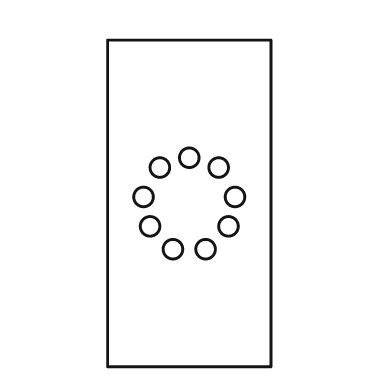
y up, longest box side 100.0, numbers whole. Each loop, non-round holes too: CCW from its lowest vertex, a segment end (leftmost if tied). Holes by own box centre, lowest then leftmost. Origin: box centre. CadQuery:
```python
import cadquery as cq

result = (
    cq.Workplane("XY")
    .moveTo(-25.0, -50.0)
    .lineTo(25.0, -50.0)
    .lineTo(25.0, 50.0)
    .lineTo(-25.0, 50.0)
    .close()
    .moveTo(-5.0, -14.0)
    .circle(3.0)
    .moveTo(5.0, -14.0)
    .circle(3.0)
    .moveTo(-12.0, -7.0)
    .circle(3.0)
    .moveTo(12.0, -7.0)
    .circle(3.0)
    .moveTo(-14.0, 2.0)
    .circle(3.0)
    .moveTo(14.0, 2.0)
    .circle(3.0)
    .moveTo(-9.0, 11.0)
    .circle(3.0)
    .moveTo(9.0, 11.0)
    .circle(3.0)
    .moveTo(0.0, 14.0)
    .circle(3.0)
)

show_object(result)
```